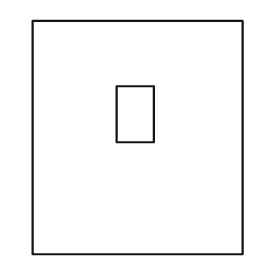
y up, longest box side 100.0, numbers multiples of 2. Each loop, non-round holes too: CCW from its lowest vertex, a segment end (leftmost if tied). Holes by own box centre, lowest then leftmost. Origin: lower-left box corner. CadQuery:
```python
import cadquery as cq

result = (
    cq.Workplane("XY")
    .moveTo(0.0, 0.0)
    .lineTo(90.0, 0.0)
    .lineTo(90.0, 100.0)
    .lineTo(0.0, 100.0)
    .close()
    .moveTo(36.0, 48.0)
    .lineTo(52.0, 48.0)
    .lineTo(52.0, 72.0)
    .lineTo(36.0, 72.0)
    .close()
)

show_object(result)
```